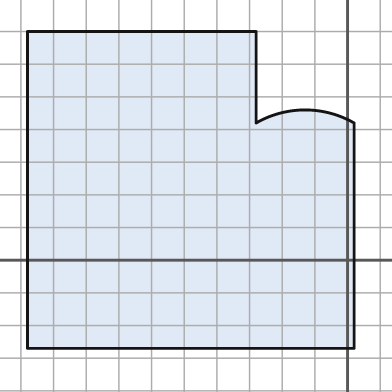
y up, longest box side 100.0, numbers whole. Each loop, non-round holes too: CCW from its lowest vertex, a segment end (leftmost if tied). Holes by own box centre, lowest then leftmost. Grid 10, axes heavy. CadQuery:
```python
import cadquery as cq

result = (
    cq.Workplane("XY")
    .moveTo(-98.0, -27.0)
    .lineTo(2.0, -27.0)
    .lineTo(2.0, 42.0)
    .threePointArc((-13.0, 46.0), (-28.0, 42.0))
    .lineTo(-28.0, 70.0)
    .lineTo(-98.0, 70.0)
    .close()
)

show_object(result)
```